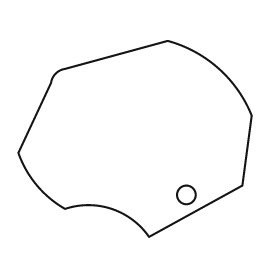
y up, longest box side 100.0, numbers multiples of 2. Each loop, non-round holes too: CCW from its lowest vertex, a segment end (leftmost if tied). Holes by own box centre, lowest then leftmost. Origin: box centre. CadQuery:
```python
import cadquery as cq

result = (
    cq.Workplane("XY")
    .moveTo(6.0, -42.0)
    .lineTo(46.0, -20.0)
    .lineTo(50.0, 10.0)
    .threePointArc((36.0, 30.0), (14.0, 42.0))
    .lineTo(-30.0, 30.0)
    .threePointArc((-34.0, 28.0), (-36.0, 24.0))
    .lineTo(-50.0, -6.0)
    .threePointArc((-42.0, -20.0), (-30.0, -30.0))
    .threePointArc((-10.0, -30.0), (6.0, -42.0))
    .close()
    .moveTo(22.0, -24.0)
    .circle(4.0)
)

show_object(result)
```